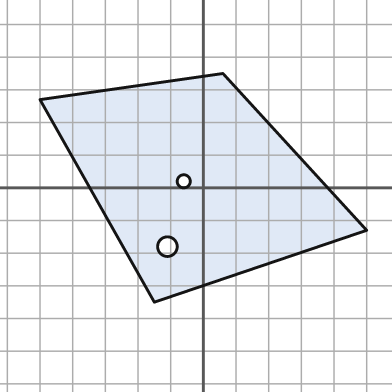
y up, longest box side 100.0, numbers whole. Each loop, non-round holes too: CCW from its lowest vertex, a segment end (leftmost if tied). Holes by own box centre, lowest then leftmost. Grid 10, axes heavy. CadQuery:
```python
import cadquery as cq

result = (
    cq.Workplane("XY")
    .moveTo(-15.0, -35.0)
    .lineTo(50.0, -13.0)
    .lineTo(6.0, 35.0)
    .lineTo(-50.0, 27.0)
    .close()
    .moveTo(-11.0, -18.0)
    .circle(3.0)
    .moveTo(-6.0, 2.0)
    .circle(2.0)
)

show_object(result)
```